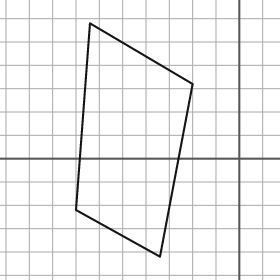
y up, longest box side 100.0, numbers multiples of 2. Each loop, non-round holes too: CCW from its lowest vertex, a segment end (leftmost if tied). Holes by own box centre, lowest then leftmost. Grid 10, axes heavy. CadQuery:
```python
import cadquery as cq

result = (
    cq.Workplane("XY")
    .moveTo(-34.0, -42.0)
    .lineTo(-20.0, 32.0)
    .lineTo(-64.0, 58.0)
    .lineTo(-70.0, -22.0)
    .close()
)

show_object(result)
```